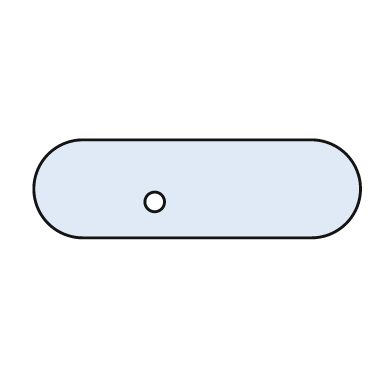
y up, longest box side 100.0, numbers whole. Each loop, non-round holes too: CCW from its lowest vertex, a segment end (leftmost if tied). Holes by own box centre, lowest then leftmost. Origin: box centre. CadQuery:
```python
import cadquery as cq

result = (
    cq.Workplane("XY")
    .moveTo(-35.0, -15.0)
    .lineTo(35.0, -15.0)
    .threePointArc((50.0, 0.0), (35.0, 15.0))
    .lineTo(-35.0, 15.0)
    .threePointArc((-50.0, 0.0), (-35.0, -15.0))
    .close()
    .moveTo(-13.0, -4.0)
    .circle(3.0)
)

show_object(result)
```